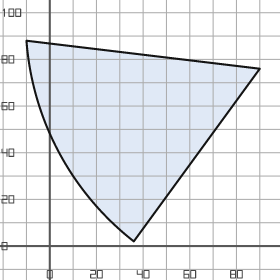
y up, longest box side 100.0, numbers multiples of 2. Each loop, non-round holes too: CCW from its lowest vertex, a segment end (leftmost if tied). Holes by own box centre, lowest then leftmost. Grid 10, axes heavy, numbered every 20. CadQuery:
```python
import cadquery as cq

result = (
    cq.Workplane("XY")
    .moveTo(36.0, 2.0)
    .lineTo(90.0, 76.0)
    .lineTo(-10.0, 88.0)
    .threePointArc((4.0, 40.0), (36.0, 2.0))
    .close()
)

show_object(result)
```